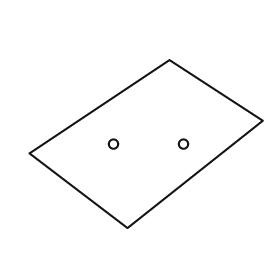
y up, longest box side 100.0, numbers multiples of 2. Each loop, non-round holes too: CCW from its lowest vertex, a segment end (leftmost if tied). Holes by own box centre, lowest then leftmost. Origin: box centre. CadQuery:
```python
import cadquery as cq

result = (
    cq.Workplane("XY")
    .moveTo(-8.0, -36.0)
    .lineTo(50.0, 10.0)
    .lineTo(10.0, 36.0)
    .lineTo(-50.0, -4.0)
    .close()
    .moveTo(-14.0, 0.0)
    .circle(2.0)
    .moveTo(16.0, 0.0)
    .circle(2.0)
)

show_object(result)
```